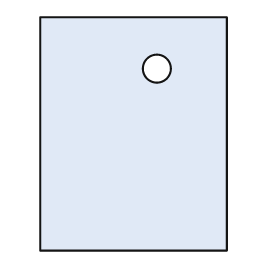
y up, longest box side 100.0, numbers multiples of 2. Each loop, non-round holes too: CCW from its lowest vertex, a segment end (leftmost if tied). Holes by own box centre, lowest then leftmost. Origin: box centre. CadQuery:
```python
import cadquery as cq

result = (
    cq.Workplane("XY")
    .moveTo(-40.0, -50.0)
    .lineTo(40.0, -50.0)
    .lineTo(40.0, 50.0)
    .lineTo(-40.0, 50.0)
    .close()
    .moveTo(10.0, 28.0)
    .circle(6.0)
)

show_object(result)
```